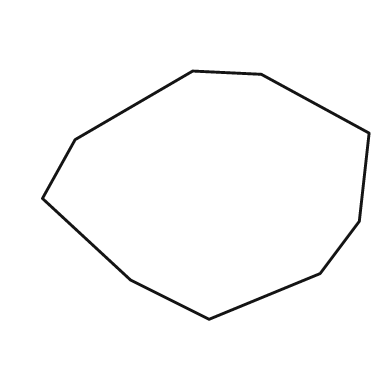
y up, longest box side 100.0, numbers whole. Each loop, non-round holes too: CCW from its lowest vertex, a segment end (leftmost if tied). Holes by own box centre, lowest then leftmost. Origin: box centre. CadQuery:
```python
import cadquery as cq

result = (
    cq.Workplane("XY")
    .moveTo(1.0, -38.0)
    .lineTo(35.0, -24.0)
    .lineTo(47.0, -8.0)
    .lineTo(50.0, 19.0)
    .lineTo(17.0, 37.0)
    .lineTo(-4.0, 38.0)
    .lineTo(-40.0, 17.0)
    .lineTo(-50.0, -1.0)
    .lineTo(-23.0, -26.0)
    .close()
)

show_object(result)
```